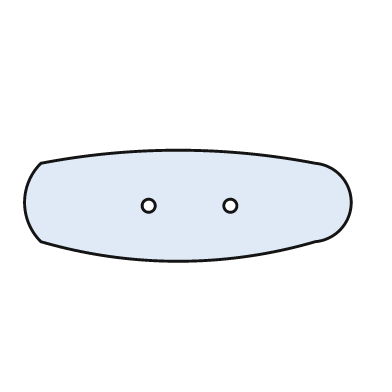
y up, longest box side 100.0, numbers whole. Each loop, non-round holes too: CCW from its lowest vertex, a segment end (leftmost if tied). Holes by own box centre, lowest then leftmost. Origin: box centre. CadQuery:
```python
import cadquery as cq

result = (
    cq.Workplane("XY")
    .moveTo(-45.0, -11.0)
    .threePointArc((-3.0, -17.0), (39.0, -11.0))
    .threePointArc((50.0, 1.0), (39.0, 13.0))
    .threePointArc((-3.0, 17.0), (-45.0, 13.0))
    .threePointArc((-50.0, 1.0), (-45.0, -11.0))
    .close()
    .moveTo(-12.0, 0.0)
    .circle(2.0)
    .moveTo(13.0, 0.0)
    .circle(2.0)
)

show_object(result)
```